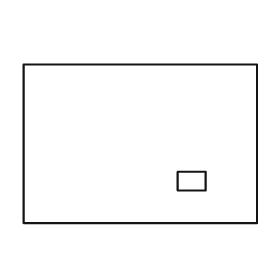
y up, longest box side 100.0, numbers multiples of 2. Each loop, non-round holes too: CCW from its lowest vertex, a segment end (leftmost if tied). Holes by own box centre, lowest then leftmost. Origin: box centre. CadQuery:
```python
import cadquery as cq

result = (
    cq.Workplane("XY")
    .moveTo(-50.0, -34.0)
    .lineTo(50.0, -34.0)
    .lineTo(50.0, 34.0)
    .lineTo(-50.0, 34.0)
    .close()
    .moveTo(16.0, -20.0)
    .lineTo(28.0, -20.0)
    .lineTo(28.0, -12.0)
    .lineTo(16.0, -12.0)
    .close()
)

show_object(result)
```